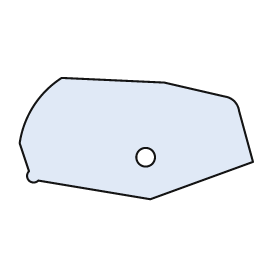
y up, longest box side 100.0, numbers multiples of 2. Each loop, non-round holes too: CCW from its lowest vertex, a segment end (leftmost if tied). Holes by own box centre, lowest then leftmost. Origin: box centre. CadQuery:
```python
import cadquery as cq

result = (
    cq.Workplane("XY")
    .moveTo(6.0, -26.0)
    .lineTo(50.0, -10.0)
    .lineTo(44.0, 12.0)
    .threePointArc((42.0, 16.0), (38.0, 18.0))
    .lineTo(12.0, 24.0)
    .lineTo(-32.0, 26.0)
    .threePointArc((-44.0, 14.0), (-50.0, -2.0))
    .lineTo(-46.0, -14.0)
    .threePointArc((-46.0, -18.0), (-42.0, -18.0))
    .close()
    .moveTo(4.0, -8.0)
    .circle(4.0)
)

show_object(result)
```